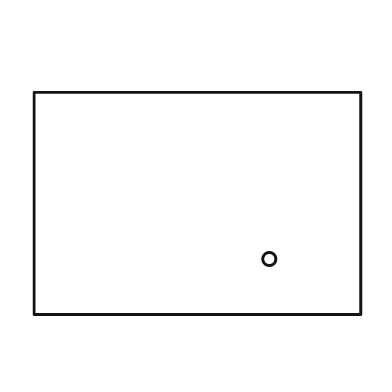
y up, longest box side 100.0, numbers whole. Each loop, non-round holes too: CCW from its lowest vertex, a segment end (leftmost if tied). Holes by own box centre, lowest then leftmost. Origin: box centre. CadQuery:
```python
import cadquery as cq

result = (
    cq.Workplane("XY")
    .moveTo(-50.0, -34.0)
    .lineTo(50.0, -34.0)
    .lineTo(50.0, 34.0)
    .lineTo(-50.0, 34.0)
    .close()
    .moveTo(22.0, -17.0)
    .circle(2.0)
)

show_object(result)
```